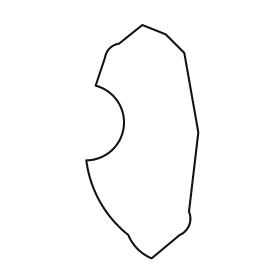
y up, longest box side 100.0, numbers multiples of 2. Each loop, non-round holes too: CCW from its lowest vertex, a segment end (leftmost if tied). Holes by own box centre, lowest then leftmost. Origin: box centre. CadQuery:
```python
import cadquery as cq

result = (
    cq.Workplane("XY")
    .moveTo(4.0, -50.0)
    .lineTo(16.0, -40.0)
    .threePointArc((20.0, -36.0), (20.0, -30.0))
    .lineTo(24.0, 4.0)
    .lineTo(18.0, 38.0)
    .lineTo(10.0, 46.0)
    .lineTo(0.0, 50.0)
    .lineTo(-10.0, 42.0)
    .threePointArc((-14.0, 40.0), (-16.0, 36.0))
    .lineTo(-20.0, 24.0)
    .threePointArc((-8.0, 6.0), (-24.0, -8.0))
    .threePointArc((-18.0, -26.0), (-6.0, -40.0))
    .threePointArc((-2.0, -46.0), (4.0, -50.0))
    .close()
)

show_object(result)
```